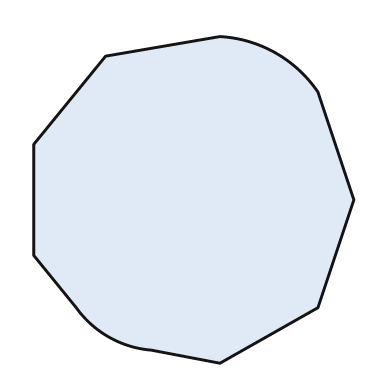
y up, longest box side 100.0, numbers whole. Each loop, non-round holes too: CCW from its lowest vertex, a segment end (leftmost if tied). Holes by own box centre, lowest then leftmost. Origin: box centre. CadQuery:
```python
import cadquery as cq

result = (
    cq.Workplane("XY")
    .moveTo(8.0, -50.0)
    .lineTo(38.0, -33.0)
    .lineTo(49.0, 0.0)
    .lineTo(38.0, 33.0)
    .threePointArc((25.0, 45.0), (8.0, 50.0))
    .lineTo(-27.0, 44.0)
    .lineTo(-49.0, 17.0)
    .lineTo(-49.0, -17.0)
    .lineTo(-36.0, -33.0)
    .threePointArc((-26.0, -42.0), (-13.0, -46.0))
    .close()
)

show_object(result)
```